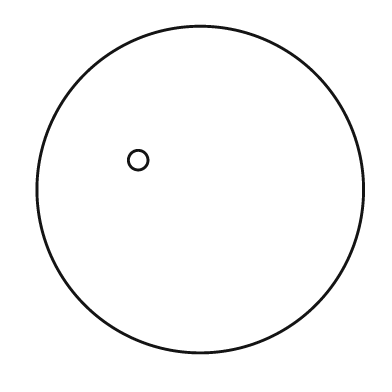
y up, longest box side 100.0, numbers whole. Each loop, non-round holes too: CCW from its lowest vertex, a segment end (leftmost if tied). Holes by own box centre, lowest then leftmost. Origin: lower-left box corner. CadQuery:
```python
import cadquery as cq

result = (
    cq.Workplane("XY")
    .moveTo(50.0, 50.0)
    .circle(50.0)
    .moveTo(31.0, 59.0)
    .circle(3.0)
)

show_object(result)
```